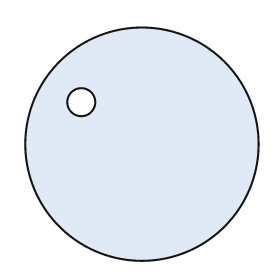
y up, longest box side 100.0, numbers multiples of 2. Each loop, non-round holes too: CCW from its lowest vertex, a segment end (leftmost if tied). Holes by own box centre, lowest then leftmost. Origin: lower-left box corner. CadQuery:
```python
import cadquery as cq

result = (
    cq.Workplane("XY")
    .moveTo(50.0, 50.0)
    .circle(50.0)
    .moveTo(24.0, 68.0)
    .circle(6.0)
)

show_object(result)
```